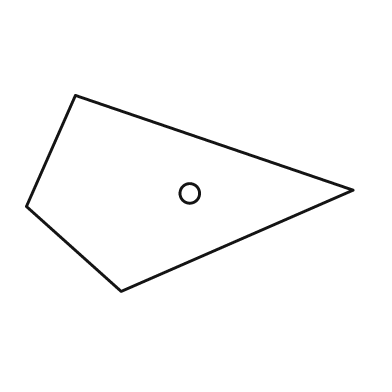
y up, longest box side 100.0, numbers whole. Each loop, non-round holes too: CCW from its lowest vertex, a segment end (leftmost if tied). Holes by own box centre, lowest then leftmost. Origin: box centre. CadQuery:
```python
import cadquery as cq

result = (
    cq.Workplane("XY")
    .moveTo(-21.0, -30.0)
    .lineTo(50.0, 1.0)
    .lineTo(-35.0, 30.0)
    .lineTo(-50.0, -4.0)
    .close()
    .moveTo(0.0, 0.0)
    .circle(3.0)
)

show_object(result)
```